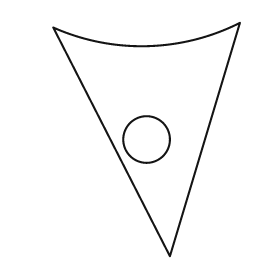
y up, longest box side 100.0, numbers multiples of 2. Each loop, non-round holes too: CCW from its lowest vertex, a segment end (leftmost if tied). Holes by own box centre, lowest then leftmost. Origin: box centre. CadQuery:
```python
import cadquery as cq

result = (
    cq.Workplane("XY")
    .moveTo(10.0, -50.0)
    .lineTo(40.0, 50.0)
    .threePointArc((0.0, 40.0), (-40.0, 48.0))
    .close()
    .moveTo(0.0, 0.0)
    .circle(10.0)
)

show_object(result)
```